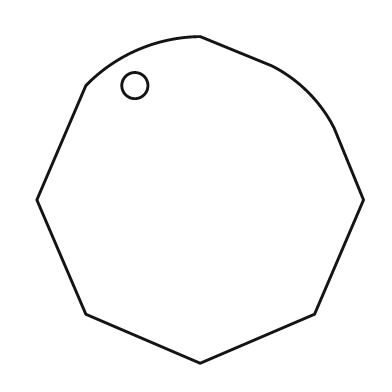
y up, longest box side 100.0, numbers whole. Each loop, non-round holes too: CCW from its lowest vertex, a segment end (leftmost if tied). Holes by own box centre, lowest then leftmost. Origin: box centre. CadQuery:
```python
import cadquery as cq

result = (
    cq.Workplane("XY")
    .moveTo(0.0, -50.0)
    .lineTo(35.0, -35.0)
    .lineTo(50.0, 0.0)
    .lineTo(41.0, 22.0)
    .threePointArc((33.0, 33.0), (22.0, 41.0))
    .lineTo(0.0, 50.0)
    .threePointArc((-19.0, 46.0), (-35.0, 35.0))
    .lineTo(-50.0, 0.0)
    .lineTo(-35.0, -35.0)
    .close()
    .moveTo(-20.0, 35.0)
    .circle(4.0)
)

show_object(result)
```